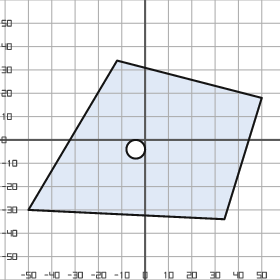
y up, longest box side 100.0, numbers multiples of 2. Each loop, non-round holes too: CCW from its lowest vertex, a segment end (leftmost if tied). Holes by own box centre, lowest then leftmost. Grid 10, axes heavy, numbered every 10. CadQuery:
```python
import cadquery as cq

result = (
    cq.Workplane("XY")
    .moveTo(34.0, -34.0)
    .lineTo(50.0, 18.0)
    .lineTo(-12.0, 34.0)
    .lineTo(-50.0, -30.0)
    .close()
    .moveTo(-4.0, -4.0)
    .circle(4.0)
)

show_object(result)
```